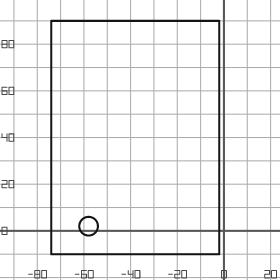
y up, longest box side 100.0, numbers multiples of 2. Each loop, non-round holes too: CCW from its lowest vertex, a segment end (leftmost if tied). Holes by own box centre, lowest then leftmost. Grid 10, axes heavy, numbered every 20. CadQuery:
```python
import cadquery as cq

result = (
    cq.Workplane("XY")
    .moveTo(-74.0, -10.0)
    .lineTo(-2.0, -10.0)
    .lineTo(-2.0, 90.0)
    .lineTo(-74.0, 90.0)
    .close()
    .moveTo(-58.0, 2.0)
    .circle(4.0)
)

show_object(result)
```